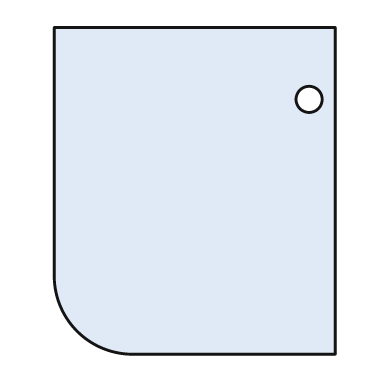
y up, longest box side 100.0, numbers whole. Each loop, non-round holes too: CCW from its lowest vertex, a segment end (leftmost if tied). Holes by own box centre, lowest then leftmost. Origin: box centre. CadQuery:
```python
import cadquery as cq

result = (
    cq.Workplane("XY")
    .moveTo(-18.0, -50.0)
    .lineTo(43.0, -50.0)
    .lineTo(43.0, 50.0)
    .lineTo(-43.0, 50.0)
    .lineTo(-43.0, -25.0)
    .threePointArc((-36.0, -43.0), (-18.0, -50.0))
    .close()
    .moveTo(35.0, 28.0)
    .circle(4.0)
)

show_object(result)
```